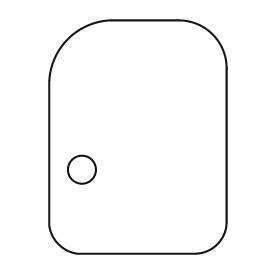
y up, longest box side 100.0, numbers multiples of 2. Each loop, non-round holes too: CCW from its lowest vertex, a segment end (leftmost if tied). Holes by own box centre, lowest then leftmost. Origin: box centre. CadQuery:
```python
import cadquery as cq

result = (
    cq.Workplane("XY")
    .moveTo(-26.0, -50.0)
    .lineTo(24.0, -50.0)
    .threePointArc((34.0, -46.0), (38.0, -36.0))
    .lineTo(38.0, 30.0)
    .threePointArc((32.0, 44.0), (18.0, 50.0))
    .lineTo(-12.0, 50.0)
    .threePointArc((-30.0, 42.0), (-38.0, 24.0))
    .lineTo(-38.0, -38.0)
    .threePointArc((-34.0, -46.0), (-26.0, -50.0))
    .close()
    .moveTo(-24.0, -14.0)
    .circle(6.0)
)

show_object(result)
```